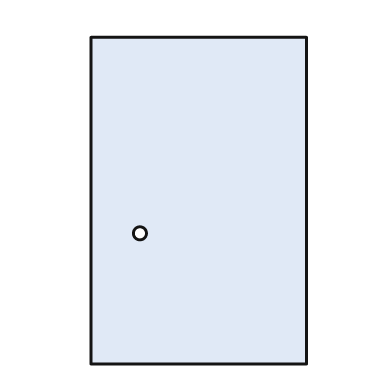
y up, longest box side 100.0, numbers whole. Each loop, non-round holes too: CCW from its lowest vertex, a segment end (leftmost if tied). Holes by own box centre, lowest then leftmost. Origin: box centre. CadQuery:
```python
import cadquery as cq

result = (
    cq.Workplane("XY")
    .moveTo(-33.0, -50.0)
    .lineTo(33.0, -50.0)
    .lineTo(33.0, 50.0)
    .lineTo(-33.0, 50.0)
    .close()
    .moveTo(-18.0, -10.0)
    .circle(2.0)
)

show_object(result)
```